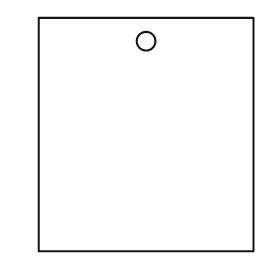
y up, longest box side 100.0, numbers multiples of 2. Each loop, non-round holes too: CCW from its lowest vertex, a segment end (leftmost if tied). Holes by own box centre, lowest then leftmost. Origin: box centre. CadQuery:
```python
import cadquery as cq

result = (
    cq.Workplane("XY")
    .moveTo(-46.0, -50.0)
    .lineTo(46.0, -50.0)
    .lineTo(46.0, 50.0)
    .lineTo(-46.0, 50.0)
    .close()
    .moveTo(0.0, 40.0)
    .circle(4.0)
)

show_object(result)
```